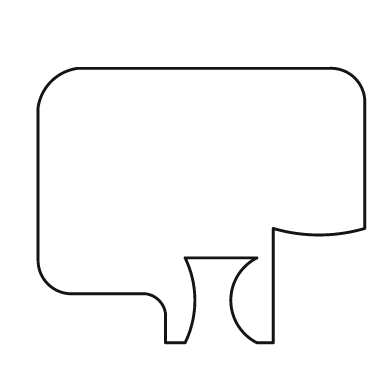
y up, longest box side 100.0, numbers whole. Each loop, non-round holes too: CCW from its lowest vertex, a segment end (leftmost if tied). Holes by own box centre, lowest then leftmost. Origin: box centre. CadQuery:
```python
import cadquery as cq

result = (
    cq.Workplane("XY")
    .moveTo(-11.0, -42.0)
    .lineTo(-5.0, -42.0)
    .threePointArc((-2.0, -29.0), (-5.0, -16.0))
    .lineTo(17.0, -16.0)
    .threePointArc((9.0, -29.0), (17.0, -42.0))
    .lineTo(22.0, -42.0)
    .lineTo(22.0, -7.0)
    .threePointArc((36.0, -9.0), (50.0, -7.0))
    .lineTo(50.0, 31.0)
    .threePointArc((47.0, 39.0), (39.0, 42.0))
    .lineTo(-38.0, 42.0)
    .threePointArc((-46.0, 38.0), (-50.0, 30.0))
    .lineTo(-50.0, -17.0)
    .threePointArc((-47.0, -24.0), (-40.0, -27.0))
    .lineTo(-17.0, -27.0)
    .threePointArc((-13.0, -29.0), (-11.0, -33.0))
    .close()
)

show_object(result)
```